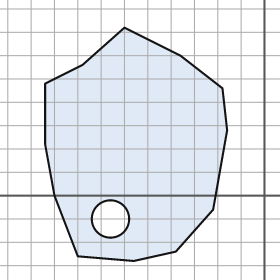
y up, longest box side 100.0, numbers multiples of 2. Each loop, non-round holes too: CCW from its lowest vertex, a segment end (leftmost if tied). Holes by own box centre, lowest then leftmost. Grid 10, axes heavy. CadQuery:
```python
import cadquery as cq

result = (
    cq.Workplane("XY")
    .moveTo(-56.0, -28.0)
    .lineTo(-38.0, -24.0)
    .lineTo(-22.0, -6.0)
    .lineTo(-16.0, 28.0)
    .lineTo(-18.0, 46.0)
    .lineTo(-36.0, 60.0)
    .lineTo(-60.0, 72.0)
    .lineTo(-78.0, 56.0)
    .lineTo(-94.0, 48.0)
    .lineTo(-94.0, 22.0)
    .lineTo(-90.0, 0.0)
    .lineTo(-80.0, -26.0)
    .close()
    .moveTo(-66.0, -10.0)
    .circle(8.0)
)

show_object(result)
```